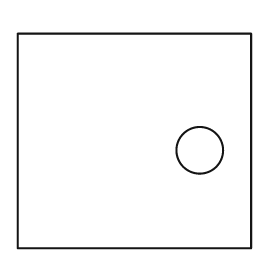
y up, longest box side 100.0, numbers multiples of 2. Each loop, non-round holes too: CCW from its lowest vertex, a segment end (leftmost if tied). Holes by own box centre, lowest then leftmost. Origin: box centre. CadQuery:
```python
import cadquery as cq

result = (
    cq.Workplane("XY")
    .moveTo(-50.0, -46.0)
    .lineTo(50.0, -46.0)
    .lineTo(50.0, 46.0)
    .lineTo(-50.0, 46.0)
    .close()
    .moveTo(28.0, -4.0)
    .circle(10.0)
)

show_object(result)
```